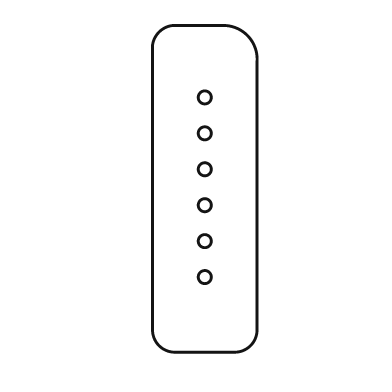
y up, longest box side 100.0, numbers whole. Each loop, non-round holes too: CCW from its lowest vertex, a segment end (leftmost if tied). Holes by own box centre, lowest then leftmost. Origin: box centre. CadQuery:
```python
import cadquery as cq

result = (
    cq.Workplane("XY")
    .moveTo(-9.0, -50.0)
    .lineTo(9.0, -50.0)
    .threePointArc((14.0, -48.0), (16.0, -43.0))
    .lineTo(16.0, 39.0)
    .threePointArc((13.0, 47.0), (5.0, 50.0))
    .lineTo(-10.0, 50.0)
    .threePointArc((-14.0, 48.0), (-16.0, 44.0))
    .lineTo(-16.0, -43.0)
    .threePointArc((-14.0, -48.0), (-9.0, -50.0))
    .close()
    .moveTo(0.0, -27.0)
    .circle(2.0)
    .moveTo(0.0, -16.0)
    .circle(2.0)
    .moveTo(0.0, -5.0)
    .circle(2.0)
    .moveTo(0.0, 6.0)
    .circle(2.0)
    .moveTo(0.0, 17.0)
    .circle(2.0)
    .moveTo(0.0, 28.0)
    .circle(2.0)
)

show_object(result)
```